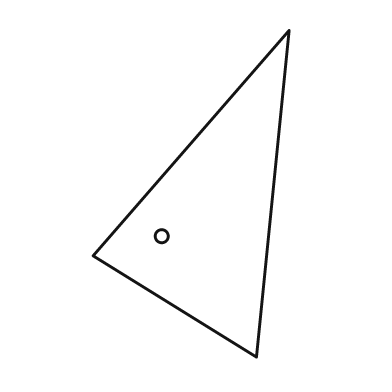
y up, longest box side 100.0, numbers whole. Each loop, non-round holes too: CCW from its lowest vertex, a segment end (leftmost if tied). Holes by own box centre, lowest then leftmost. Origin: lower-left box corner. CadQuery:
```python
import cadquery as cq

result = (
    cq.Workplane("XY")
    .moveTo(50.0, 0.0)
    .lineTo(60.0, 100.0)
    .lineTo(0.0, 31.0)
    .close()
    .moveTo(21.0, 37.0)
    .circle(2.0)
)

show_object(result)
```